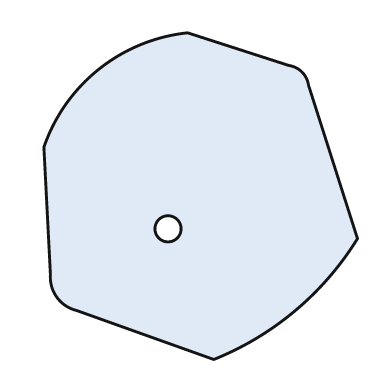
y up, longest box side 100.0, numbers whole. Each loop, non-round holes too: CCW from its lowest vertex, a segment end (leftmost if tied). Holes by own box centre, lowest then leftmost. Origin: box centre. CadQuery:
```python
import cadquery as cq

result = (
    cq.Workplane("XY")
    .moveTo(4.0, -50.0)
    .threePointArc((29.0, -35.0), (48.0, -13.0))
    .lineTo(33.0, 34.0)
    .threePointArc((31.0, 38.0), (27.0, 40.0))
    .lineTo(-4.0, 50.0)
    .threePointArc((-31.0, 39.0), (-48.0, 15.0))
    .lineTo(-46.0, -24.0)
    .threePointArc((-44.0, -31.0), (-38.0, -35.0))
    .close()
    .moveTo(-10.0, -10.0)
    .circle(4.0)
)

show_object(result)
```